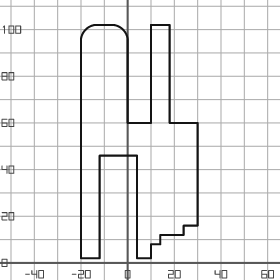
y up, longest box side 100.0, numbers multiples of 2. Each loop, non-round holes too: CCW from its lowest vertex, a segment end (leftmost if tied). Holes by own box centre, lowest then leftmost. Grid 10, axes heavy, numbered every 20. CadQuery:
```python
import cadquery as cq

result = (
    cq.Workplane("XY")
    .moveTo(-20.0, 2.0)
    .lineTo(-12.0, 2.0)
    .lineTo(-12.0, 46.0)
    .lineTo(4.0, 46.0)
    .lineTo(4.0, 2.0)
    .lineTo(10.0, 2.0)
    .lineTo(10.0, 8.0)
    .lineTo(14.0, 8.0)
    .lineTo(14.0, 12.0)
    .lineTo(24.0, 12.0)
    .lineTo(24.0, 16.0)
    .lineTo(30.0, 16.0)
    .lineTo(30.0, 60.0)
    .lineTo(18.0, 60.0)
    .lineTo(18.0, 102.0)
    .lineTo(10.0, 102.0)
    .lineTo(10.0, 60.0)
    .lineTo(0.0, 60.0)
    .lineTo(0.0, 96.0)
    .threePointArc((-2.0, 100.0), (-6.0, 102.0))
    .lineTo(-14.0, 102.0)
    .threePointArc((-18.0, 100.0), (-20.0, 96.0))
    .close()
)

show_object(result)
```